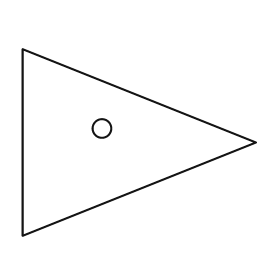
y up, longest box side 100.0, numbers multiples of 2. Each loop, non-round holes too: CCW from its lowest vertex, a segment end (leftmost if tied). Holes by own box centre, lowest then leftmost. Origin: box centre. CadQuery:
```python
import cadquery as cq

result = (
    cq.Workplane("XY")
    .moveTo(-50.0, -40.0)
    .lineTo(50.0, 0.0)
    .lineTo(-50.0, 40.0)
    .close()
    .moveTo(-16.0, 6.0)
    .circle(4.0)
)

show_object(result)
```